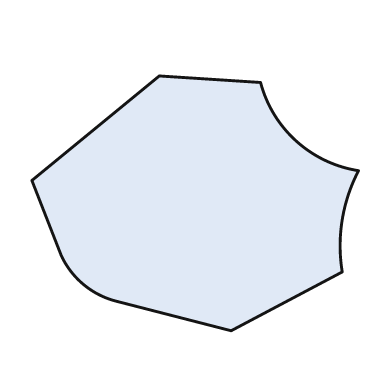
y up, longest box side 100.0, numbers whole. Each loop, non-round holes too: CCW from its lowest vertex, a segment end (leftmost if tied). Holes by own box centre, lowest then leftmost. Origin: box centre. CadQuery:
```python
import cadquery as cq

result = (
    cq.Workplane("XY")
    .moveTo(11.0, -39.0)
    .lineTo(45.0, -21.0)
    .threePointArc((45.0, -5.0), (50.0, 10.0))
    .threePointArc((31.0, 19.0), (20.0, 37.0))
    .lineTo(-11.0, 39.0)
    .lineTo(-50.0, 7.0)
    .lineTo(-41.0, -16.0)
    .threePointArc((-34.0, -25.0), (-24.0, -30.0))
    .close()
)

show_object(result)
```